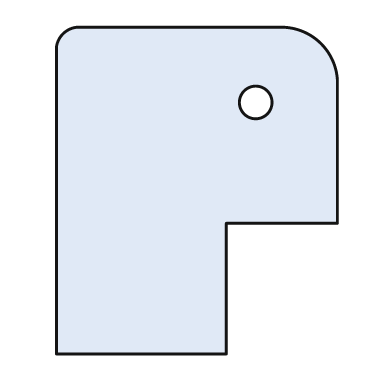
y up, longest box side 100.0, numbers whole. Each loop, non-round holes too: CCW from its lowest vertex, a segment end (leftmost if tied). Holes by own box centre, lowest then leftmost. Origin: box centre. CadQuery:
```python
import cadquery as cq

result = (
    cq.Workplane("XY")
    .moveTo(-43.0, -50.0)
    .lineTo(9.0, -50.0)
    .lineTo(9.0, -10.0)
    .lineTo(43.0, -10.0)
    .lineTo(43.0, 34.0)
    .threePointArc((38.0, 45.0), (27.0, 50.0))
    .lineTo(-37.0, 50.0)
    .threePointArc((-41.0, 48.0), (-43.0, 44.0))
    .close()
    .moveTo(18.0, 27.0)
    .circle(5.0)
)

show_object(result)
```